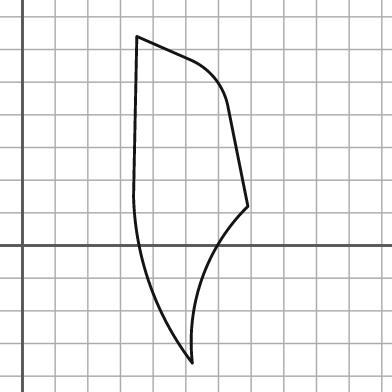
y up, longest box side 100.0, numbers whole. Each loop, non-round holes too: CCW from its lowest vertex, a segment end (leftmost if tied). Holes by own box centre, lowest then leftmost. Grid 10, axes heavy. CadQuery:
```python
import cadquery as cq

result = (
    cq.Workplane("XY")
    .moveTo(52.0, -36.0)
    .threePointArc((55.0, -10.0), (69.0, 12.0))
    .lineTo(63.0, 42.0)
    .threePointArc((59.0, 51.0), (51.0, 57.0))
    .lineTo(35.0, 64.0)
    .lineTo(34.0, 15.0)
    .threePointArc((39.0, -12.0), (52.0, -36.0))
    .close()
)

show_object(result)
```